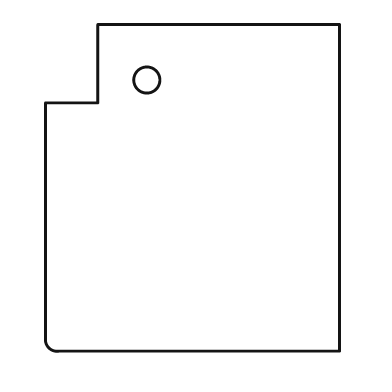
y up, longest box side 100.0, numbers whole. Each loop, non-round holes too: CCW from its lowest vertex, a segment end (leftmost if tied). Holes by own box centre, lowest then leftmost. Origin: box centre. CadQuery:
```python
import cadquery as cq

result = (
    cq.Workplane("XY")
    .moveTo(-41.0, -50.0)
    .lineTo(45.0, -50.0)
    .lineTo(45.0, 50.0)
    .lineTo(-29.0, 50.0)
    .lineTo(-29.0, 26.0)
    .lineTo(-45.0, 26.0)
    .lineTo(-45.0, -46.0)
    .threePointArc((-44.0, -49.0), (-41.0, -50.0))
    .close()
    .moveTo(-14.0, 33.0)
    .circle(4.0)
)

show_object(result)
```